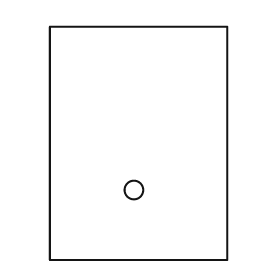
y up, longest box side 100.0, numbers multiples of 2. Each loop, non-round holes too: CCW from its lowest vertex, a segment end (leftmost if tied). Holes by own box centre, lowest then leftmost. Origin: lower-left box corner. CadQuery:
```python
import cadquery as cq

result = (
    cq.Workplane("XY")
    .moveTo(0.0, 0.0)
    .lineTo(76.0, 0.0)
    .lineTo(76.0, 100.0)
    .lineTo(0.0, 100.0)
    .close()
    .moveTo(36.0, 30.0)
    .circle(4.0)
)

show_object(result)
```